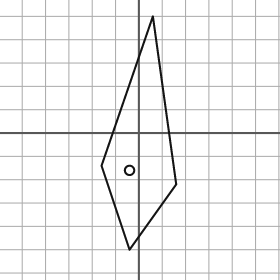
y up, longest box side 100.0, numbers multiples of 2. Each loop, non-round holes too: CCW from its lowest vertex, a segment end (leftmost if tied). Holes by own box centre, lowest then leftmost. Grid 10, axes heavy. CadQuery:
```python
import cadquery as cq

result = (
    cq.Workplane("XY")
    .moveTo(-4.0, -50.0)
    .lineTo(16.0, -22.0)
    .lineTo(6.0, 50.0)
    .lineTo(-16.0, -14.0)
    .close()
    .moveTo(-4.0, -16.0)
    .circle(2.0)
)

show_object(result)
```